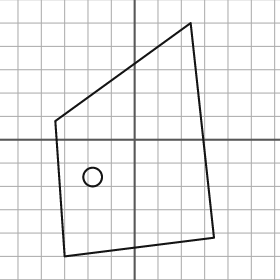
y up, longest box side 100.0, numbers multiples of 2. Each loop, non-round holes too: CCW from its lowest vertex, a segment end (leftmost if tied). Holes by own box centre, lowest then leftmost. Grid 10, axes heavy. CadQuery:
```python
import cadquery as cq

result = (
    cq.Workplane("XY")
    .moveTo(-30.0, -50.0)
    .lineTo(34.0, -42.0)
    .lineTo(24.0, 50.0)
    .lineTo(-34.0, 8.0)
    .close()
    .moveTo(-18.0, -16.0)
    .circle(4.0)
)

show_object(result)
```